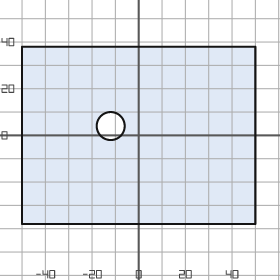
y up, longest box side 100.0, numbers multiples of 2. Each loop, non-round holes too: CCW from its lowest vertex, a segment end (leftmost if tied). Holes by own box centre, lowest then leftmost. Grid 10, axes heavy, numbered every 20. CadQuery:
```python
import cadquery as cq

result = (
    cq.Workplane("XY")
    .moveTo(-50.0, -38.0)
    .lineTo(50.0, -38.0)
    .lineTo(50.0, 38.0)
    .lineTo(-50.0, 38.0)
    .close()
    .moveTo(-12.0, 4.0)
    .circle(6.0)
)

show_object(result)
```